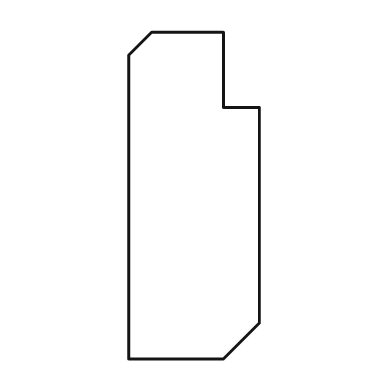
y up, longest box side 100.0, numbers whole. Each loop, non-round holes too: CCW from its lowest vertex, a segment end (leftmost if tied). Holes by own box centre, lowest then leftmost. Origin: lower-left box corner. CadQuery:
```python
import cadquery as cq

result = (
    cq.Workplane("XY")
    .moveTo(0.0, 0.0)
    .lineTo(29.0, 0.0)
    .lineTo(40.0, 11.0)
    .lineTo(40.0, 77.0)
    .lineTo(29.0, 77.0)
    .lineTo(29.0, 100.0)
    .lineTo(7.0, 100.0)
    .lineTo(0.0, 93.0)
    .close()
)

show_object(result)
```